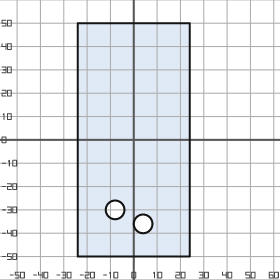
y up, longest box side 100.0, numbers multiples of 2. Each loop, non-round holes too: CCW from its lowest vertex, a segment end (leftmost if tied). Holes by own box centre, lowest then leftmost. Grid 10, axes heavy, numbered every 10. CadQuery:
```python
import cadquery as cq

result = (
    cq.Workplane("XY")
    .moveTo(-24.0, -50.0)
    .lineTo(24.0, -50.0)
    .lineTo(24.0, 50.0)
    .lineTo(-24.0, 50.0)
    .close()
    .moveTo(4.0, -36.0)
    .circle(4.0)
    .moveTo(-8.0, -30.0)
    .circle(4.0)
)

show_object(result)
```